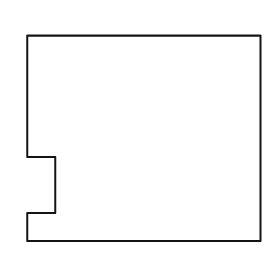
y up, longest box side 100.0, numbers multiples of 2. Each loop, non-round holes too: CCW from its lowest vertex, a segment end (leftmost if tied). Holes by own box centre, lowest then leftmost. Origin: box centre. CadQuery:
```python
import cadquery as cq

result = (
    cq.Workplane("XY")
    .moveTo(-50.0, -44.0)
    .lineTo(50.0, -44.0)
    .lineTo(50.0, 44.0)
    .lineTo(-50.0, 44.0)
    .lineTo(-50.0, -8.0)
    .lineTo(-38.0, -8.0)
    .lineTo(-38.0, -32.0)
    .lineTo(-50.0, -32.0)
    .close()
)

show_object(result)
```